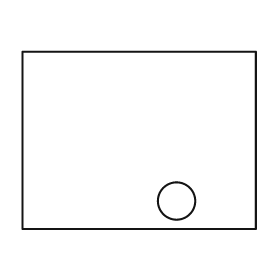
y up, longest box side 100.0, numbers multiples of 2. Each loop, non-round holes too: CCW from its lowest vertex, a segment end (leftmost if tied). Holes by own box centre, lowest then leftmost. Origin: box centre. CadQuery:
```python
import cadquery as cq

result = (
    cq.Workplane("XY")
    .moveTo(-50.0, -38.0)
    .lineTo(50.0, -38.0)
    .lineTo(50.0, 38.0)
    .lineTo(-50.0, 38.0)
    .close()
    .moveTo(16.0, -26.0)
    .circle(8.0)
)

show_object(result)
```